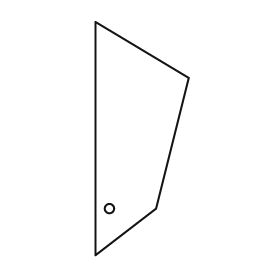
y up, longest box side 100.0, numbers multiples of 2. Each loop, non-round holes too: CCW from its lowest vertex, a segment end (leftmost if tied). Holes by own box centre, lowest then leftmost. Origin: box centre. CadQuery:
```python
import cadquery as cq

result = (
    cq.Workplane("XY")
    .moveTo(-20.0, -50.0)
    .lineTo(6.0, -30.0)
    .lineTo(20.0, 26.0)
    .lineTo(-20.0, 50.0)
    .close()
    .moveTo(-14.0, -30.0)
    .circle(2.0)
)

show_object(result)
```